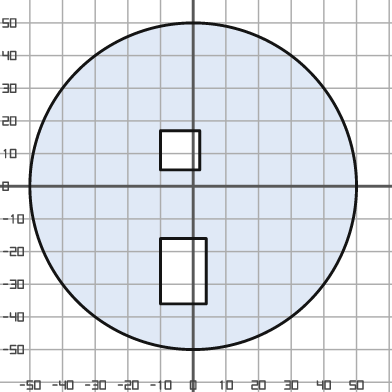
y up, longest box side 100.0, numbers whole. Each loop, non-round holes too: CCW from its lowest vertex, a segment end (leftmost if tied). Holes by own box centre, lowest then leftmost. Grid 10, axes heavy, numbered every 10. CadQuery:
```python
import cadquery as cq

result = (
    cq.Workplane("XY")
    .moveTo(0.0, 0.0)
    .circle(50.0)
    .moveTo(-10.0, -36.0)
    .lineTo(4.0, -36.0)
    .lineTo(4.0, -16.0)
    .lineTo(-10.0, -16.0)
    .close()
    .moveTo(-10.0, 5.0)
    .lineTo(2.0, 5.0)
    .lineTo(2.0, 17.0)
    .lineTo(-10.0, 17.0)
    .close()
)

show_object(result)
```